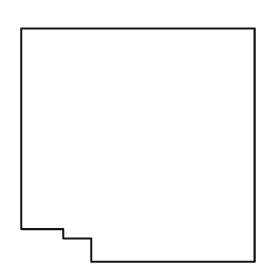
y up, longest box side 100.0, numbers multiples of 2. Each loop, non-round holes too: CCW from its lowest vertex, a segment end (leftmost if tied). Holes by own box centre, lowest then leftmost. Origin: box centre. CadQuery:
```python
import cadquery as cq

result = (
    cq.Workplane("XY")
    .moveTo(-20.0, -50.0)
    .lineTo(50.0, -50.0)
    .lineTo(50.0, 50.0)
    .lineTo(-50.0, 50.0)
    .lineTo(-50.0, -36.0)
    .lineTo(-32.0, -36.0)
    .lineTo(-32.0, -40.0)
    .lineTo(-20.0, -40.0)
    .close()
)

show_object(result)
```